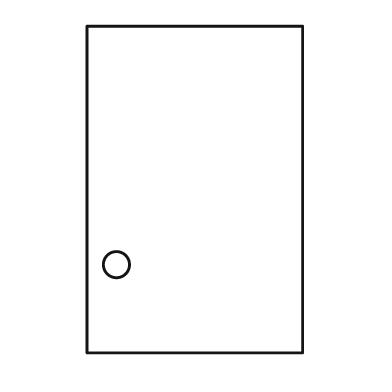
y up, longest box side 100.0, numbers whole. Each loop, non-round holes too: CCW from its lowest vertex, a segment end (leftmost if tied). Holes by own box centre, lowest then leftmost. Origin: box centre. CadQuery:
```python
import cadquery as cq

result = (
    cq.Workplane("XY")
    .moveTo(-33.0, -50.0)
    .lineTo(33.0, -50.0)
    .lineTo(33.0, 50.0)
    .lineTo(-33.0, 50.0)
    .close()
    .moveTo(-24.0, -23.0)
    .circle(4.0)
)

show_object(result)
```